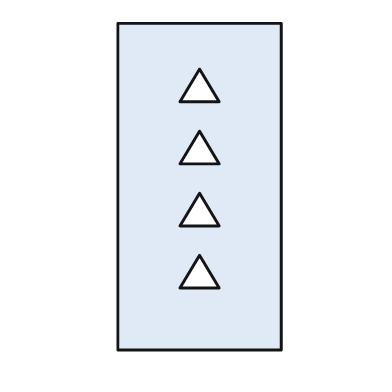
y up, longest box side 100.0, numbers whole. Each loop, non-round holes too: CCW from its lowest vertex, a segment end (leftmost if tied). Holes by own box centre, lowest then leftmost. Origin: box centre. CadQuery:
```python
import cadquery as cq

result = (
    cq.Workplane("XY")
    .moveTo(-25.0, -50.0)
    .lineTo(25.0, -50.0)
    .lineTo(25.0, 50.0)
    .lineTo(-25.0, 50.0)
    .close()
    .moveTo(-6.0, -31.0)
    .lineTo(6.0, -31.0)
    .lineTo(0.0, -21.0)
    .close()
    .moveTo(-6.0, -12.0)
    .lineTo(6.0, -12.0)
    .lineTo(0.0, -2.0)
    .close()
    .moveTo(-6.0, 7.0)
    .lineTo(6.0, 7.0)
    .lineTo(0.0, 17.0)
    .close()
    .moveTo(-6.0, 26.0)
    .lineTo(6.0, 26.0)
    .lineTo(0.0, 36.0)
    .close()
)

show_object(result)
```